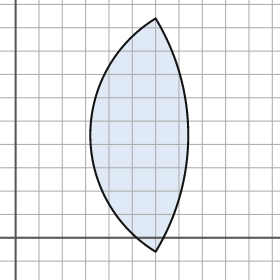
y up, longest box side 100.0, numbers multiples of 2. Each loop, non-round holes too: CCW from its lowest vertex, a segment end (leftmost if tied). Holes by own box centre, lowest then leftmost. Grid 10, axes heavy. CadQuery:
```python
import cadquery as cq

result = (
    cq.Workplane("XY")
    .moveTo(60.0, -6.0)
    .threePointArc((74.0, 44.0), (60.0, 94.0))
    .threePointArc((32.0, 44.0), (60.0, -6.0))
    .close()
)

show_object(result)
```